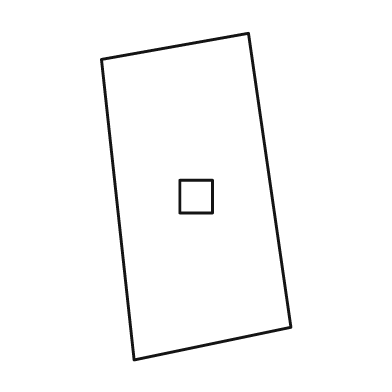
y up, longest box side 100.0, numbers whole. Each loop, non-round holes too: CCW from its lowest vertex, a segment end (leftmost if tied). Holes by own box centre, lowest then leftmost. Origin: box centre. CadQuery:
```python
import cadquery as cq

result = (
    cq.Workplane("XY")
    .moveTo(-19.0, -50.0)
    .lineTo(29.0, -40.0)
    .lineTo(16.0, 50.0)
    .lineTo(-29.0, 42.0)
    .close()
    .moveTo(-5.0, -5.0)
    .lineTo(5.0, -5.0)
    .lineTo(5.0, 5.0)
    .lineTo(-5.0, 5.0)
    .close()
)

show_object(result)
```